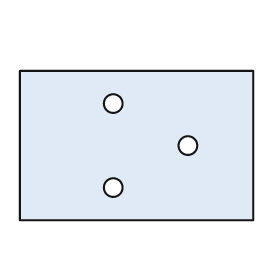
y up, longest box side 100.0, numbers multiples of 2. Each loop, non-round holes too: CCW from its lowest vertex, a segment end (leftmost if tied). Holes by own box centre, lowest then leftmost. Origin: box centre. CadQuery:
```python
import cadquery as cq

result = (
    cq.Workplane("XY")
    .moveTo(-50.0, -32.0)
    .lineTo(50.0, -32.0)
    .lineTo(50.0, 32.0)
    .lineTo(-50.0, 32.0)
    .close()
    .moveTo(-10.0, -18.0)
    .circle(4.0)
    .moveTo(22.0, 0.0)
    .circle(4.0)
    .moveTo(-10.0, 18.0)
    .circle(4.0)
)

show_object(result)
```